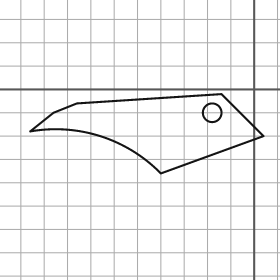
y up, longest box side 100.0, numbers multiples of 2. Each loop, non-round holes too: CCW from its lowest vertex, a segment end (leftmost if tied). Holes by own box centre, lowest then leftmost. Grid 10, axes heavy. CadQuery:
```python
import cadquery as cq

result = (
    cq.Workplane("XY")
    .moveTo(-40.0, -36.0)
    .lineTo(4.0, -20.0)
    .lineTo(-14.0, -2.0)
    .lineTo(-76.0, -6.0)
    .lineTo(-86.0, -10.0)
    .lineTo(-96.0, -18.0)
    .threePointArc((-66.0, -20.0), (-40.0, -36.0))
    .close()
    .moveTo(-18.0, -10.0)
    .circle(4.0)
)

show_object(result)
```